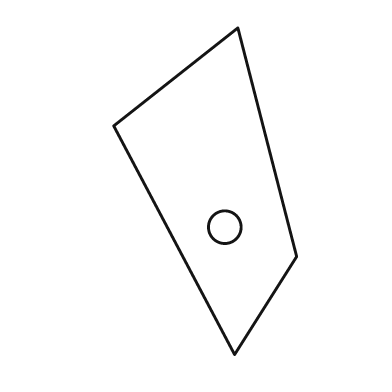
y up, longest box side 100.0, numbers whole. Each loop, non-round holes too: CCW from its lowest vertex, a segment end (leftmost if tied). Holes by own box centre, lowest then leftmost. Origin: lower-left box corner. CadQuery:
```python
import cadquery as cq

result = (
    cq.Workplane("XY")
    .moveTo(37.0, 0.0)
    .lineTo(56.0, 30.0)
    .lineTo(38.0, 100.0)
    .lineTo(0.0, 70.0)
    .close()
    .moveTo(34.0, 39.0)
    .circle(5.0)
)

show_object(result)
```